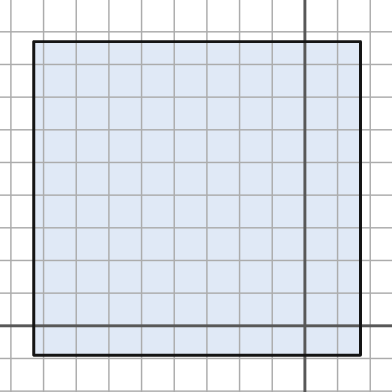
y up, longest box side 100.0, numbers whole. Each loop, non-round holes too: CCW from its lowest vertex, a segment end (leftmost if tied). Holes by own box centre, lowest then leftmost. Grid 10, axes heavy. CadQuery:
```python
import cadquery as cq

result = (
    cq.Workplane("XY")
    .moveTo(-83.0, -9.0)
    .lineTo(17.0, -9.0)
    .lineTo(17.0, 87.0)
    .lineTo(-83.0, 87.0)
    .close()
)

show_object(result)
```